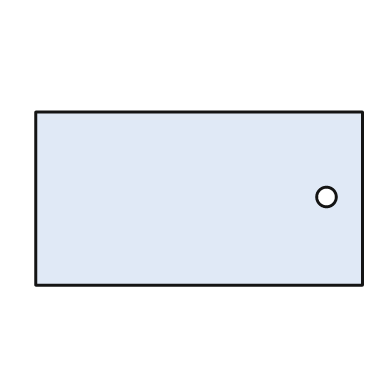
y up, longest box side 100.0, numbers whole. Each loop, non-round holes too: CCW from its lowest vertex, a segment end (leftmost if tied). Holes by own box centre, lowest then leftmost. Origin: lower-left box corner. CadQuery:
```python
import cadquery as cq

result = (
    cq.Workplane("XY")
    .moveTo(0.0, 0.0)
    .lineTo(100.0, 0.0)
    .lineTo(100.0, 53.0)
    .lineTo(0.0, 53.0)
    .close()
    .moveTo(89.0, 27.0)
    .circle(3.0)
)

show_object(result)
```